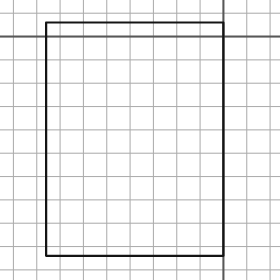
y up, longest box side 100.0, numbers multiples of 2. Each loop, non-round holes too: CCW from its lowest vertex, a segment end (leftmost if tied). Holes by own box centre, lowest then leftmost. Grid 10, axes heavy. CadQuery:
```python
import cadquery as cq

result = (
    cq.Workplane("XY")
    .moveTo(-76.0, -94.0)
    .lineTo(0.0, -94.0)
    .lineTo(0.0, 6.0)
    .lineTo(-76.0, 6.0)
    .close()
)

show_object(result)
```